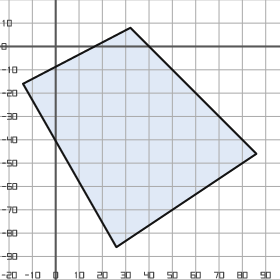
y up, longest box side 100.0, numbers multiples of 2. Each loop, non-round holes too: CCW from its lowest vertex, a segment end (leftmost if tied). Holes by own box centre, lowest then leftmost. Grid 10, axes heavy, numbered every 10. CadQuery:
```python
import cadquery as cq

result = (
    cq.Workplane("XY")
    .moveTo(26.0, -86.0)
    .lineTo(86.0, -46.0)
    .lineTo(32.0, 8.0)
    .lineTo(-14.0, -16.0)
    .close()
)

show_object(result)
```